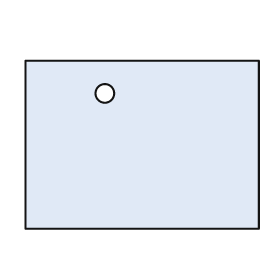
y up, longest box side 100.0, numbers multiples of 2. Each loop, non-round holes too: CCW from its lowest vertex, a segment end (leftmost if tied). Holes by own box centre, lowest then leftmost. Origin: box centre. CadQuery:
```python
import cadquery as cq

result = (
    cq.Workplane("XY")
    .moveTo(-50.0, -36.0)
    .lineTo(50.0, -36.0)
    .lineTo(50.0, 36.0)
    .lineTo(-50.0, 36.0)
    .close()
    .moveTo(-16.0, 22.0)
    .circle(4.0)
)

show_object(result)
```